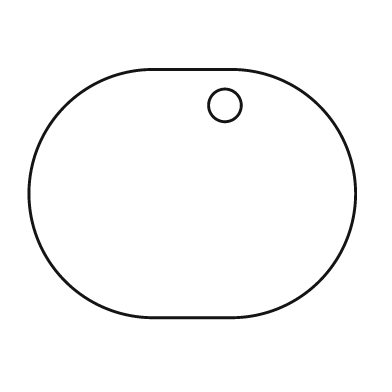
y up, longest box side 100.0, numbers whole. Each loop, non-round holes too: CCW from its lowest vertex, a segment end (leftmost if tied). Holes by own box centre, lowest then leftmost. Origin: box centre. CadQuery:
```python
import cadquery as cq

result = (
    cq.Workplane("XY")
    .moveTo(-12.0, -38.0)
    .lineTo(12.0, -38.0)
    .threePointArc((50.0, 0.0), (12.0, 38.0))
    .lineTo(-12.0, 38.0)
    .threePointArc((-50.0, 0.0), (-12.0, -38.0))
    .close()
    .moveTo(10.0, 27.0)
    .circle(5.0)
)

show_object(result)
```